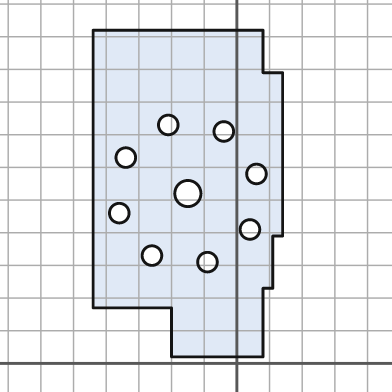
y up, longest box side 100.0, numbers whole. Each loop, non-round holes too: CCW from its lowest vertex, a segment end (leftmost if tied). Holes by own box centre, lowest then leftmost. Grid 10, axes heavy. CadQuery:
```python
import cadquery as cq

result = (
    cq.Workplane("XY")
    .moveTo(-20.0, 2.0)
    .lineTo(8.0, 2.0)
    .lineTo(8.0, 23.0)
    .lineTo(11.0, 23.0)
    .lineTo(11.0, 39.0)
    .lineTo(14.0, 39.0)
    .lineTo(14.0, 89.0)
    .lineTo(8.0, 89.0)
    .lineTo(8.0, 102.0)
    .lineTo(-44.0, 102.0)
    .lineTo(-44.0, 17.0)
    .lineTo(-20.0, 17.0)
    .close()
    .moveTo(-9.0, 31.0)
    .circle(3.0)
    .moveTo(-26.0, 33.0)
    .circle(3.0)
    .moveTo(4.0, 41.0)
    .circle(3.0)
    .moveTo(-36.0, 46.0)
    .circle(3.0)
    .moveTo(-15.0, 52.0)
    .circle(4.0)
    .moveTo(6.0, 58.0)
    .circle(3.0)
    .moveTo(-34.0, 63.0)
    .circle(3.0)
    .moveTo(-4.0, 71.0)
    .circle(3.0)
    .moveTo(-21.0, 73.0)
    .circle(3.0)
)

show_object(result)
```